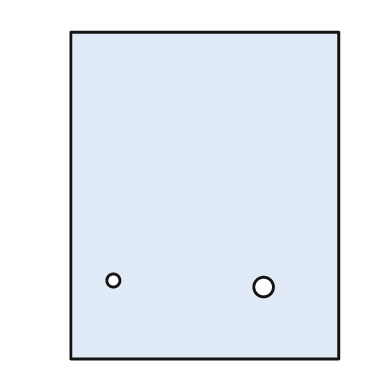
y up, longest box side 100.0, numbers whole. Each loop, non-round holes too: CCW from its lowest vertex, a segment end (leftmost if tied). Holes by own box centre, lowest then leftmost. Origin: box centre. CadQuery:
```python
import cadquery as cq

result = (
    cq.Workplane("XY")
    .moveTo(-41.0, -50.0)
    .lineTo(41.0, -50.0)
    .lineTo(41.0, 50.0)
    .lineTo(-41.0, 50.0)
    .close()
    .moveTo(18.0, -28.0)
    .circle(3.0)
    .moveTo(-28.0, -26.0)
    .circle(2.0)
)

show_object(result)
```